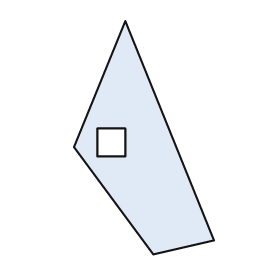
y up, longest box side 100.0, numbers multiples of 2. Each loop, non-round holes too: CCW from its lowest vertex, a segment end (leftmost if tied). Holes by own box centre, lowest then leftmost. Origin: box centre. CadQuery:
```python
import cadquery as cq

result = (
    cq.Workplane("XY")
    .moveTo(4.0, -50.0)
    .lineTo(30.0, -44.0)
    .lineTo(-8.0, 50.0)
    .lineTo(-30.0, -4.0)
    .close()
    .moveTo(-20.0, -8.0)
    .lineTo(-8.0, -8.0)
    .lineTo(-8.0, 4.0)
    .lineTo(-20.0, 4.0)
    .close()
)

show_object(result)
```